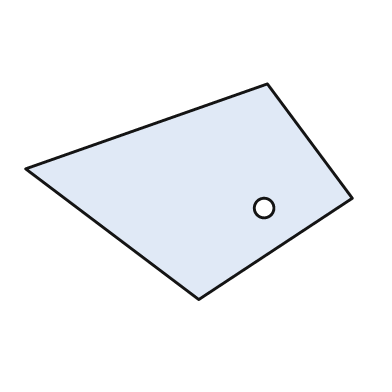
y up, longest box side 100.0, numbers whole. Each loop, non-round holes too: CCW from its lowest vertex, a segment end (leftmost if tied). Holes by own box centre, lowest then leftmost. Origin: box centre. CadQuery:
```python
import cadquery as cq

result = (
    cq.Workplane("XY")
    .moveTo(3.0, -33.0)
    .lineTo(50.0, -2.0)
    .lineTo(24.0, 33.0)
    .lineTo(-50.0, 7.0)
    .close()
    .moveTo(23.0, -5.0)
    .circle(3.0)
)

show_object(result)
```